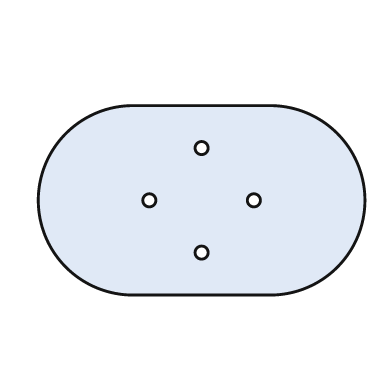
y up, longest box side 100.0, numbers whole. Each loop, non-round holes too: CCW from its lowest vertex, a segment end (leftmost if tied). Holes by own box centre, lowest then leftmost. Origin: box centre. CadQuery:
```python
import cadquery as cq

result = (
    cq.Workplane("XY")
    .moveTo(-21.0, -29.0)
    .lineTo(21.0, -29.0)
    .threePointArc((50.0, 0.0), (21.0, 29.0))
    .lineTo(-21.0, 29.0)
    .threePointArc((-50.0, 0.0), (-21.0, -29.0))
    .close()
    .moveTo(0.0, -16.0)
    .circle(2.0)
    .moveTo(-16.0, 0.0)
    .circle(2.0)
    .moveTo(16.0, 0.0)
    .circle(2.0)
    .moveTo(0.0, 16.0)
    .circle(2.0)
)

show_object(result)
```